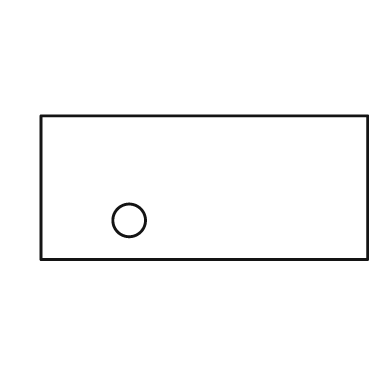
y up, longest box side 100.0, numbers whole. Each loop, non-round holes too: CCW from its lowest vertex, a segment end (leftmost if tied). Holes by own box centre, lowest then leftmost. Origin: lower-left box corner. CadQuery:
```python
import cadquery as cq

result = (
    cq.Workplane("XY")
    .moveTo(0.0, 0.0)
    .lineTo(100.0, 0.0)
    .lineTo(100.0, 44.0)
    .lineTo(0.0, 44.0)
    .close()
    .moveTo(27.0, 12.0)
    .circle(5.0)
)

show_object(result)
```